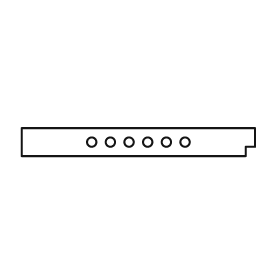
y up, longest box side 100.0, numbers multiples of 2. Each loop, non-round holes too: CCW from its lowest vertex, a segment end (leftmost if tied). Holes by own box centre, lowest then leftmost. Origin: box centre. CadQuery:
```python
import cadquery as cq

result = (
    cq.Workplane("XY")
    .moveTo(-50.0, -6.0)
    .lineTo(46.0, -6.0)
    .lineTo(46.0, -2.0)
    .lineTo(50.0, -2.0)
    .lineTo(50.0, 6.0)
    .lineTo(-50.0, 6.0)
    .close()
    .moveTo(-20.0, 0.0)
    .circle(2.0)
    .moveTo(-12.0, 0.0)
    .circle(2.0)
    .moveTo(-4.0, 0.0)
    .circle(2.0)
    .moveTo(4.0, 0.0)
    .circle(2.0)
    .moveTo(12.0, 0.0)
    .circle(2.0)
    .moveTo(20.0, 0.0)
    .circle(2.0)
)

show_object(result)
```